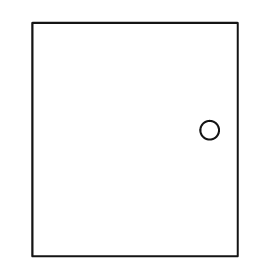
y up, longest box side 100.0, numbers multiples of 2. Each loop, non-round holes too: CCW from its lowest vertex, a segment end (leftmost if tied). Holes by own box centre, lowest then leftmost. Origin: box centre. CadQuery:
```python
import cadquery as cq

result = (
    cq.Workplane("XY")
    .moveTo(-44.0, -50.0)
    .lineTo(44.0, -50.0)
    .lineTo(44.0, 50.0)
    .lineTo(-44.0, 50.0)
    .close()
    .moveTo(32.0, 4.0)
    .circle(4.0)
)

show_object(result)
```